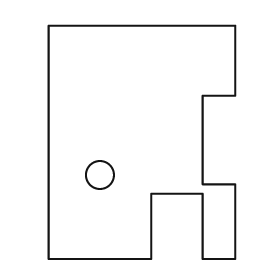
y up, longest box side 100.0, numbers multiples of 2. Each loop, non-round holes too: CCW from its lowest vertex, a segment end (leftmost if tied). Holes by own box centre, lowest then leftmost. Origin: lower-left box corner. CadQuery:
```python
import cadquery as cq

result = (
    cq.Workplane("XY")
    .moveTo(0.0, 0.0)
    .lineTo(44.0, 0.0)
    .lineTo(44.0, 28.0)
    .lineTo(66.0, 28.0)
    .lineTo(66.0, 0.0)
    .lineTo(80.0, 0.0)
    .lineTo(80.0, 32.0)
    .lineTo(66.0, 32.0)
    .lineTo(66.0, 70.0)
    .lineTo(80.0, 70.0)
    .lineTo(80.0, 100.0)
    .lineTo(0.0, 100.0)
    .close()
    .moveTo(22.0, 36.0)
    .circle(6.0)
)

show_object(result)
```